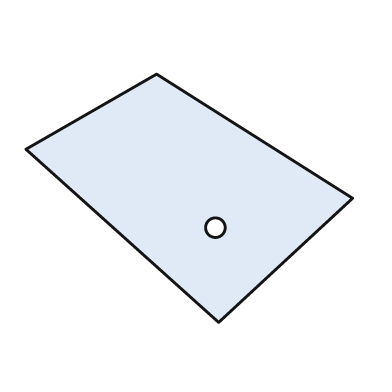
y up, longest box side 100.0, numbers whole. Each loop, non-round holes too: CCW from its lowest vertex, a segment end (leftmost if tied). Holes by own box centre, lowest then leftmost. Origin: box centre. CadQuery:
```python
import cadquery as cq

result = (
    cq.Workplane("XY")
    .moveTo(9.0, -38.0)
    .lineTo(50.0, 0.0)
    .lineTo(-10.0, 38.0)
    .lineTo(-50.0, 15.0)
    .close()
    .moveTo(8.0, -9.0)
    .circle(3.0)
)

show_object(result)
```